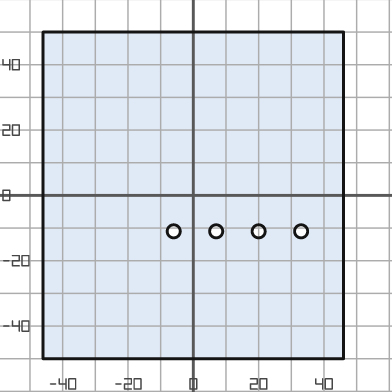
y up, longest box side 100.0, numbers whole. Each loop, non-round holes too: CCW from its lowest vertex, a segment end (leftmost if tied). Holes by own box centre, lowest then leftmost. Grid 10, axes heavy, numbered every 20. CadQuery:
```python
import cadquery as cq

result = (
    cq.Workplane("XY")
    .moveTo(-46.0, -50.0)
    .lineTo(46.0, -50.0)
    .lineTo(46.0, 50.0)
    .lineTo(-46.0, 50.0)
    .close()
    .moveTo(-6.0, -11.0)
    .circle(2.0)
    .moveTo(7.0, -11.0)
    .circle(2.0)
    .moveTo(20.0, -11.0)
    .circle(2.0)
    .moveTo(33.0, -11.0)
    .circle(2.0)
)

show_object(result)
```